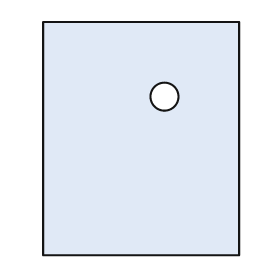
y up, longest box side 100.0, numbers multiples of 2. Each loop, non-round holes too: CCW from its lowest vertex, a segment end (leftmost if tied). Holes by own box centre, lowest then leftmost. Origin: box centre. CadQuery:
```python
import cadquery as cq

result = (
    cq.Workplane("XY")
    .moveTo(-42.0, -50.0)
    .lineTo(42.0, -50.0)
    .lineTo(42.0, 50.0)
    .lineTo(-42.0, 50.0)
    .close()
    .moveTo(10.0, 18.0)
    .circle(6.0)
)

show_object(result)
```